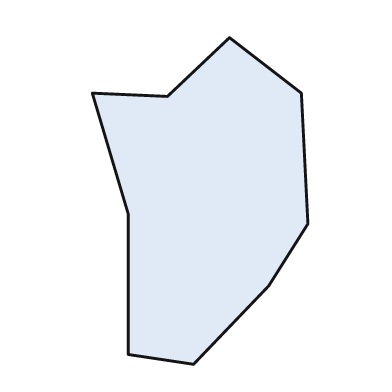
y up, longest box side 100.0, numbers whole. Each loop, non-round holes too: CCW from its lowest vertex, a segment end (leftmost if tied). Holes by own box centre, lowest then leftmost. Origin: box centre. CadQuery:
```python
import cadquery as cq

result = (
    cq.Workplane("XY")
    .moveTo(-2.0, -50.0)
    .lineTo(21.0, -26.0)
    .lineTo(33.0, -7.0)
    .lineTo(31.0, 33.0)
    .lineTo(9.0, 50.0)
    .lineTo(-10.0, 32.0)
    .lineTo(-33.0, 33.0)
    .lineTo(-22.0, -4.0)
    .lineTo(-22.0, -47.0)
    .close()
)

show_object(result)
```